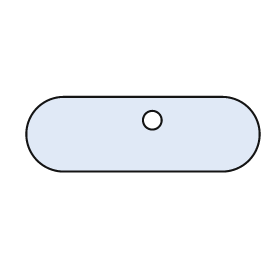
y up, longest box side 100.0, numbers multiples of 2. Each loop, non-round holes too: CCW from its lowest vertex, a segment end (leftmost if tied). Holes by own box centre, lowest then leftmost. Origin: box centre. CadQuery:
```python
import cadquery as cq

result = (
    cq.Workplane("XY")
    .moveTo(-34.0, -16.0)
    .lineTo(34.0, -16.0)
    .threePointArc((50.0, 0.0), (34.0, 16.0))
    .lineTo(-34.0, 16.0)
    .threePointArc((-50.0, 0.0), (-34.0, -16.0))
    .close()
    .moveTo(4.0, 6.0)
    .circle(4.0)
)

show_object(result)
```